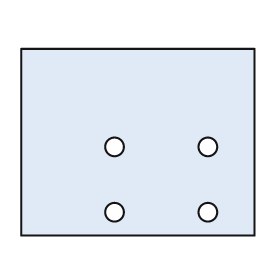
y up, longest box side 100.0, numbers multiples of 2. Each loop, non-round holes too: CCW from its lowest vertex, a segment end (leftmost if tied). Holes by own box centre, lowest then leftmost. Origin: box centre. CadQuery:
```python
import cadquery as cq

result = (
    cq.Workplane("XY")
    .moveTo(-50.0, -40.0)
    .lineTo(50.0, -40.0)
    .lineTo(50.0, 40.0)
    .lineTo(-50.0, 40.0)
    .close()
    .moveTo(-10.0, -30.0)
    .circle(4.0)
    .moveTo(30.0, -30.0)
    .circle(4.0)
    .moveTo(-10.0, -2.0)
    .circle(4.0)
    .moveTo(30.0, -2.0)
    .circle(4.0)
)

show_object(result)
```